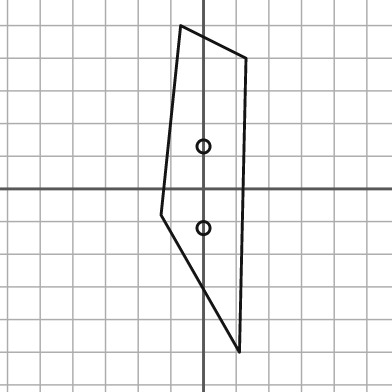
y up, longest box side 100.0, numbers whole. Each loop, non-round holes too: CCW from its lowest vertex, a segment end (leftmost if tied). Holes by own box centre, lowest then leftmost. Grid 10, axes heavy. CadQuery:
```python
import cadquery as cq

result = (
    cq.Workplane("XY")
    .moveTo(11.0, -50.0)
    .lineTo(13.0, 40.0)
    .lineTo(-7.0, 50.0)
    .lineTo(-13.0, -8.0)
    .close()
    .moveTo(0.0, -12.0)
    .circle(2.0)
    .moveTo(0.0, 13.0)
    .circle(2.0)
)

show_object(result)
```